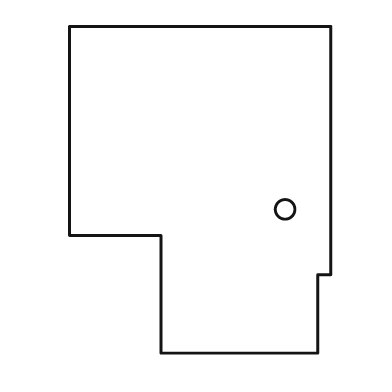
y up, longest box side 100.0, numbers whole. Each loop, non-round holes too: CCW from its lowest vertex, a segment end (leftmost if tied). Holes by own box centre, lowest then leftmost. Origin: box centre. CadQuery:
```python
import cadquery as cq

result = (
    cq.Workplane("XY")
    .moveTo(-12.0, -50.0)
    .lineTo(36.0, -50.0)
    .lineTo(36.0, -26.0)
    .lineTo(40.0, -26.0)
    .lineTo(40.0, 50.0)
    .lineTo(-40.0, 50.0)
    .lineTo(-40.0, -14.0)
    .lineTo(-12.0, -14.0)
    .close()
    .moveTo(26.0, -6.0)
    .circle(3.0)
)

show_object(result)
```